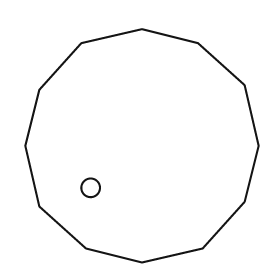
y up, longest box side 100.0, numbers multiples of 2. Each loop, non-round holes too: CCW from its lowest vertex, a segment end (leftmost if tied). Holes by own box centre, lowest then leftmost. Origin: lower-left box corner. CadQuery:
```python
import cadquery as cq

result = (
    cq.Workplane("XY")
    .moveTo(50.0, 0.0)
    .lineTo(76.0, 6.0)
    .lineTo(94.0, 26.0)
    .lineTo(100.0, 50.0)
    .lineTo(94.0, 76.0)
    .lineTo(74.0, 94.0)
    .lineTo(50.0, 100.0)
    .lineTo(24.0, 94.0)
    .lineTo(6.0, 74.0)
    .lineTo(0.0, 50.0)
    .lineTo(6.0, 24.0)
    .lineTo(26.0, 6.0)
    .close()
    .moveTo(28.0, 32.0)
    .circle(4.0)
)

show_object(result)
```